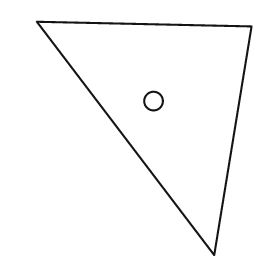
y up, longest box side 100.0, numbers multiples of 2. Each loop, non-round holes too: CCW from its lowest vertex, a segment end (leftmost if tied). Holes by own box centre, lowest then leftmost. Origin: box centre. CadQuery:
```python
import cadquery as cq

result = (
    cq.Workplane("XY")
    .moveTo(30.0, -50.0)
    .lineTo(46.0, 48.0)
    .lineTo(-46.0, 50.0)
    .close()
    .moveTo(4.0, 16.0)
    .circle(4.0)
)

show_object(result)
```